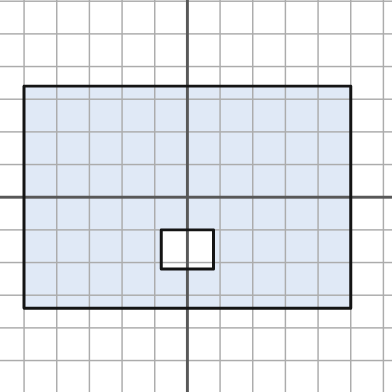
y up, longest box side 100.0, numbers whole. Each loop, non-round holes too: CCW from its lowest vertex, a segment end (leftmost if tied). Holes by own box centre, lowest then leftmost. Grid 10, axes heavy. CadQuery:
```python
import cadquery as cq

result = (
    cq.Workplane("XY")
    .moveTo(-50.0, -34.0)
    .lineTo(50.0, -34.0)
    .lineTo(50.0, 34.0)
    .lineTo(-50.0, 34.0)
    .close()
    .moveTo(-8.0, -22.0)
    .lineTo(8.0, -22.0)
    .lineTo(8.0, -10.0)
    .lineTo(-8.0, -10.0)
    .close()
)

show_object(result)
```